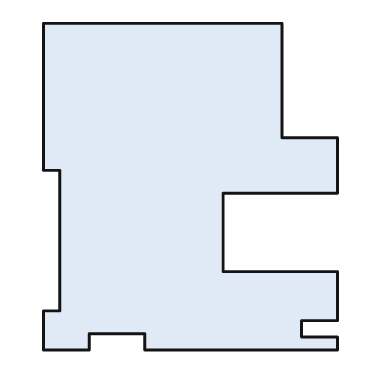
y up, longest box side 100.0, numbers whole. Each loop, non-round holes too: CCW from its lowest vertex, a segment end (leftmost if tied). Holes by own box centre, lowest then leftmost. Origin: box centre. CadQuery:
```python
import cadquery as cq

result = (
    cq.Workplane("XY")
    .moveTo(-45.0, -50.0)
    .lineTo(-31.0, -50.0)
    .lineTo(-31.0, -45.0)
    .lineTo(-14.0, -45.0)
    .lineTo(-14.0, -50.0)
    .lineTo(45.0, -50.0)
    .lineTo(45.0, -46.0)
    .lineTo(34.0, -46.0)
    .lineTo(34.0, -41.0)
    .lineTo(45.0, -41.0)
    .lineTo(45.0, -26.0)
    .lineTo(10.0, -26.0)
    .lineTo(10.0, -2.0)
    .lineTo(45.0, -2.0)
    .lineTo(45.0, 15.0)
    .lineTo(28.0, 15.0)
    .lineTo(28.0, 50.0)
    .lineTo(-45.0, 50.0)
    .lineTo(-45.0, 5.0)
    .lineTo(-40.0, 5.0)
    .lineTo(-40.0, -38.0)
    .lineTo(-45.0, -38.0)
    .close()
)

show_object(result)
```